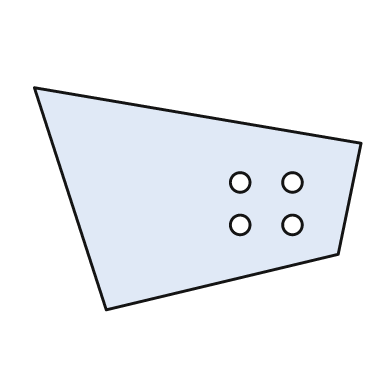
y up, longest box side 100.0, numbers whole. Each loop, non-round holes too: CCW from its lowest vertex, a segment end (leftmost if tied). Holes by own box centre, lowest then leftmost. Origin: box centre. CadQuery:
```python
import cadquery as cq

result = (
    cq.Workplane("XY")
    .moveTo(-28.0, -34.0)
    .lineTo(43.0, -17.0)
    .lineTo(50.0, 17.0)
    .lineTo(-50.0, 34.0)
    .close()
    .moveTo(13.0, -8.0)
    .circle(3.0)
    .moveTo(29.0, -8.0)
    .circle(3.0)
    .moveTo(13.0, 5.0)
    .circle(3.0)
    .moveTo(29.0, 5.0)
    .circle(3.0)
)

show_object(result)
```